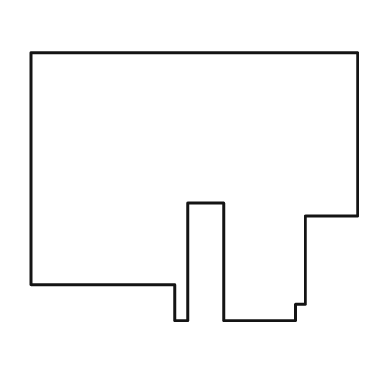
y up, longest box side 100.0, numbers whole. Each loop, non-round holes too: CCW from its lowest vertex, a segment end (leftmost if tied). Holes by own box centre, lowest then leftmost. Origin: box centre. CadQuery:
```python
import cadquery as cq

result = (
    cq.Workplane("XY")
    .moveTo(-6.0, -41.0)
    .lineTo(-2.0, -41.0)
    .lineTo(-2.0, -5.0)
    .lineTo(9.0, -5.0)
    .lineTo(9.0, -41.0)
    .lineTo(31.0, -41.0)
    .lineTo(31.0, -36.0)
    .lineTo(34.0, -36.0)
    .lineTo(34.0, -9.0)
    .lineTo(50.0, -9.0)
    .lineTo(50.0, 41.0)
    .lineTo(-50.0, 41.0)
    .lineTo(-50.0, -30.0)
    .lineTo(-6.0, -30.0)
    .close()
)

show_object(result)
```